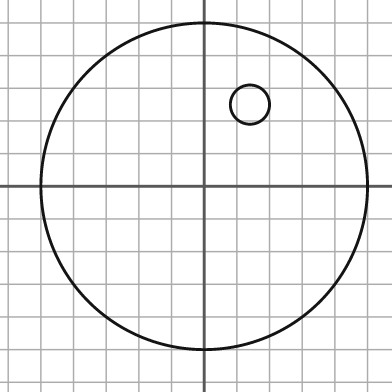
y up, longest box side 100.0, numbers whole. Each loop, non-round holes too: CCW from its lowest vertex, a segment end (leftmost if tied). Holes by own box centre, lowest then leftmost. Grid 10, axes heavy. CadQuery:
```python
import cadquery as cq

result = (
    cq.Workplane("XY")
    .moveTo(0.0, 0.0)
    .circle(50.0)
    .moveTo(14.0, 25.0)
    .circle(6.0)
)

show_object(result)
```